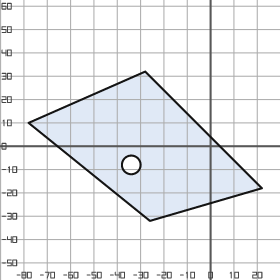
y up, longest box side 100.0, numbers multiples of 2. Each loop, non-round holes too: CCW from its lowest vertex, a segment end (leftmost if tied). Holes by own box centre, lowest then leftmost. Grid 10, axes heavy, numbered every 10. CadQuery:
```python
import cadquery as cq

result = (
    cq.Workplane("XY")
    .moveTo(-26.0, -32.0)
    .lineTo(22.0, -18.0)
    .lineTo(-28.0, 32.0)
    .lineTo(-78.0, 10.0)
    .close()
    .moveTo(-34.0, -8.0)
    .circle(4.0)
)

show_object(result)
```